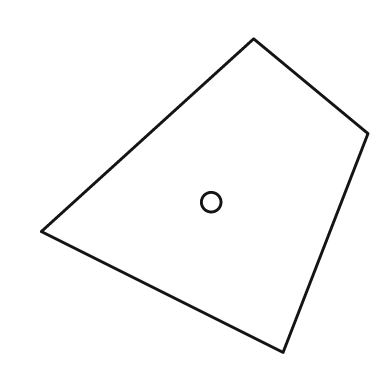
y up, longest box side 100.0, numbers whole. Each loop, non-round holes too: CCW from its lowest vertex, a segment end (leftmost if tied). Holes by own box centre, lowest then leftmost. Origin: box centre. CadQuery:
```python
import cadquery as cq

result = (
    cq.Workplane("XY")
    .moveTo(24.0, -48.0)
    .lineTo(50.0, 19.0)
    .lineTo(15.0, 48.0)
    .lineTo(-50.0, -11.0)
    .close()
    .moveTo(2.0, -2.0)
    .circle(3.0)
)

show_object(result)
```